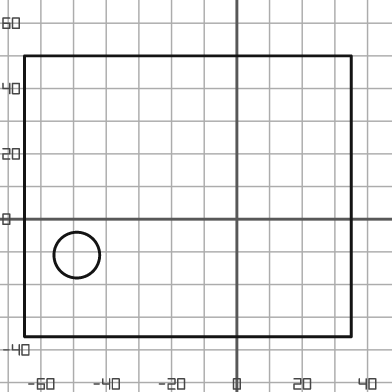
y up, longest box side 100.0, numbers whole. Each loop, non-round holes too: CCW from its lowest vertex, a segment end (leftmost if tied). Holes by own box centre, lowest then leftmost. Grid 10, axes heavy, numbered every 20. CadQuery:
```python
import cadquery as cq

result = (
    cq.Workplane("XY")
    .moveTo(-65.0, -36.0)
    .lineTo(35.0, -36.0)
    .lineTo(35.0, 50.0)
    .lineTo(-65.0, 50.0)
    .close()
    .moveTo(-49.0, -11.0)
    .circle(7.0)
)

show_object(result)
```